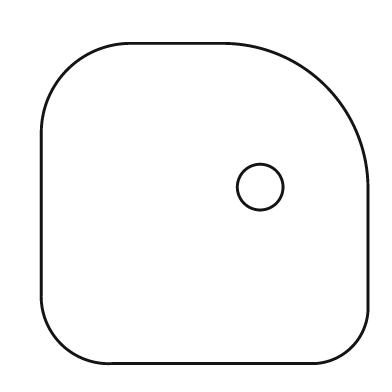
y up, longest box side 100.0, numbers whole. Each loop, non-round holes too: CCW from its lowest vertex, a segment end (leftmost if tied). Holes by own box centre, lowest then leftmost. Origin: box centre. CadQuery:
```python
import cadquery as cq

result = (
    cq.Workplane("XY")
    .moveTo(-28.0, -49.0)
    .lineTo(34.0, -49.0)
    .threePointArc((45.0, -44.0), (50.0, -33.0))
    .lineTo(50.0, 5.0)
    .threePointArc((37.0, 36.0), (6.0, 49.0))
    .lineTo(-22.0, 49.0)
    .threePointArc((-42.0, 41.0), (-50.0, 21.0))
    .lineTo(-50.0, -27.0)
    .threePointArc((-44.0, -43.0), (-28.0, -49.0))
    .close()
    .moveTo(17.0, 5.0)
    .circle(7.0)
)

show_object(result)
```